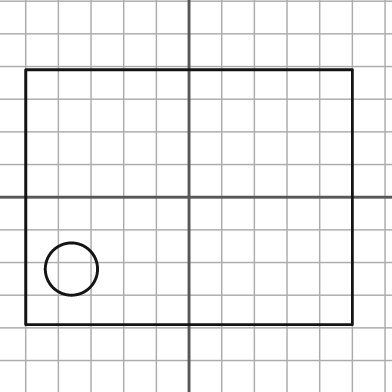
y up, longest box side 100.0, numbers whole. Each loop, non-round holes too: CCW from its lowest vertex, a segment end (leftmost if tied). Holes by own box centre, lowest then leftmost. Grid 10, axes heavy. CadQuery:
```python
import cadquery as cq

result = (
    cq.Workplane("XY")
    .moveTo(-50.0, -39.0)
    .lineTo(50.0, -39.0)
    .lineTo(50.0, 39.0)
    .lineTo(-50.0, 39.0)
    .close()
    .moveTo(-36.0, -22.0)
    .circle(8.0)
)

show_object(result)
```